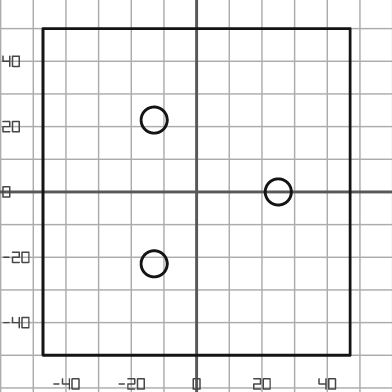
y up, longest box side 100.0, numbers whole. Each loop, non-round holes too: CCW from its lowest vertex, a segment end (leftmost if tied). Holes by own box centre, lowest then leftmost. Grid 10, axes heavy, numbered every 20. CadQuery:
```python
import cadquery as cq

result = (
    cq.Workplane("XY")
    .moveTo(-47.0, -50.0)
    .lineTo(47.0, -50.0)
    .lineTo(47.0, 50.0)
    .lineTo(-47.0, 50.0)
    .close()
    .moveTo(-13.0, -22.0)
    .circle(4.0)
    .moveTo(25.0, 0.0)
    .circle(4.0)
    .moveTo(-13.0, 22.0)
    .circle(4.0)
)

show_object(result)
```